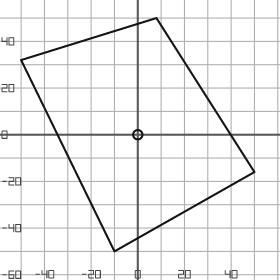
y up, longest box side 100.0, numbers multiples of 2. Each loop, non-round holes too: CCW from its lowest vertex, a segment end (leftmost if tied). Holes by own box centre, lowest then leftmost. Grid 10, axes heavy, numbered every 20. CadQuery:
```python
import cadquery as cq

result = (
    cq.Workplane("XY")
    .moveTo(-10.0, -50.0)
    .lineTo(50.0, -16.0)
    .lineTo(8.0, 50.0)
    .lineTo(-50.0, 32.0)
    .close()
    .moveTo(0.0, 0.0)
    .circle(2.0)
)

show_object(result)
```